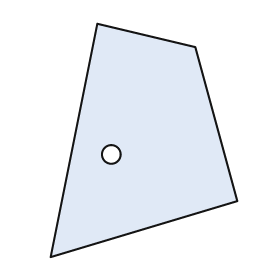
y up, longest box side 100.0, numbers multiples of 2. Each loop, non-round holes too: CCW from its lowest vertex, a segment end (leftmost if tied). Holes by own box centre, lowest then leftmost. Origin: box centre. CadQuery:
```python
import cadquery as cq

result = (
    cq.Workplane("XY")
    .moveTo(-40.0, -50.0)
    .lineTo(40.0, -26.0)
    .lineTo(22.0, 40.0)
    .lineTo(-20.0, 50.0)
    .close()
    .moveTo(-14.0, -6.0)
    .circle(4.0)
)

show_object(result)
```